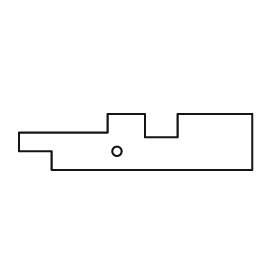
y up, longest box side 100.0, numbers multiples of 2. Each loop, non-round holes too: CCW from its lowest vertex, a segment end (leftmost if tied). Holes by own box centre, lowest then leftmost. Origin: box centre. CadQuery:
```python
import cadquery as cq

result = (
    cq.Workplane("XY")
    .moveTo(-36.0, -12.0)
    .lineTo(50.0, -12.0)
    .lineTo(50.0, 12.0)
    .lineTo(18.0, 12.0)
    .lineTo(18.0, 2.0)
    .lineTo(4.0, 2.0)
    .lineTo(4.0, 12.0)
    .lineTo(-12.0, 12.0)
    .lineTo(-12.0, 4.0)
    .lineTo(-50.0, 4.0)
    .lineTo(-50.0, -4.0)
    .lineTo(-36.0, -4.0)
    .close()
    .moveTo(-8.0, -4.0)
    .circle(2.0)
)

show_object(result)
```